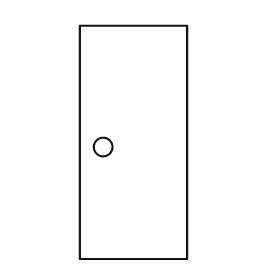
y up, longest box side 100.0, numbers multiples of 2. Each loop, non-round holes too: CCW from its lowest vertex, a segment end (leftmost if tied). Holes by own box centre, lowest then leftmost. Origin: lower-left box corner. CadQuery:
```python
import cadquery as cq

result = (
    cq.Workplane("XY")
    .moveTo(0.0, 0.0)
    .lineTo(46.0, 0.0)
    .lineTo(46.0, 100.0)
    .lineTo(0.0, 100.0)
    .close()
    .moveTo(10.0, 48.0)
    .circle(4.0)
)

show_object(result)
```